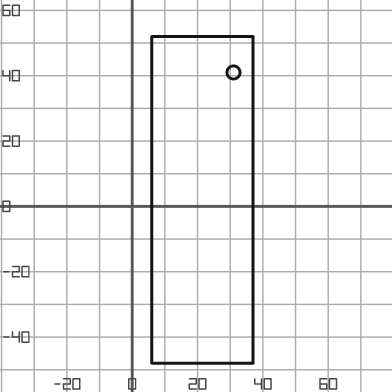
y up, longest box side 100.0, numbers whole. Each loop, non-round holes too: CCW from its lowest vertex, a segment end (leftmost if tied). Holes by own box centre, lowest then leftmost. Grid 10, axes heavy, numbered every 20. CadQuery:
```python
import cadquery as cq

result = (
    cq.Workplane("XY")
    .moveTo(6.0, -48.0)
    .lineTo(37.0, -48.0)
    .lineTo(37.0, 52.0)
    .lineTo(6.0, 52.0)
    .close()
    .moveTo(31.0, 41.0)
    .circle(2.0)
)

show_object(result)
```